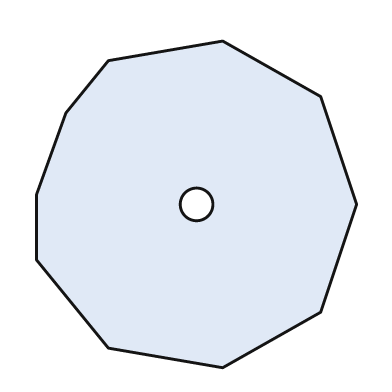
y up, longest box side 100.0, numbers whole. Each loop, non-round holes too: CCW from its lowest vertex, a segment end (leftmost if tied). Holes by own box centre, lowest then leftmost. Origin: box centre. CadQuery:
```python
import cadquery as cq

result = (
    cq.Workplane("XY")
    .moveTo(8.0, -50.0)
    .lineTo(38.0, -33.0)
    .lineTo(49.0, 0.0)
    .lineTo(38.0, 33.0)
    .lineTo(8.0, 50.0)
    .lineTo(-27.0, 44.0)
    .lineTo(-40.0, 28.0)
    .lineTo(-49.0, 3.0)
    .lineTo(-49.0, -17.0)
    .lineTo(-27.0, -44.0)
    .close()
    .moveTo(0.0, 0.0)
    .circle(5.0)
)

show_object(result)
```